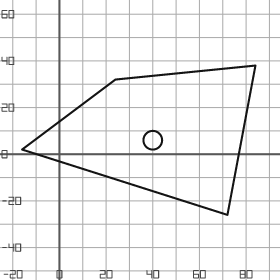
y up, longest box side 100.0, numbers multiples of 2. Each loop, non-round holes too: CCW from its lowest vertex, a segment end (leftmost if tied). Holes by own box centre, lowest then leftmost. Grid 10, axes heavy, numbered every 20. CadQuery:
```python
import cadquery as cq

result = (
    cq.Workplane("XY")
    .moveTo(72.0, -26.0)
    .lineTo(84.0, 38.0)
    .lineTo(24.0, 32.0)
    .lineTo(-16.0, 2.0)
    .close()
    .moveTo(40.0, 6.0)
    .circle(4.0)
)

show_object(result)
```